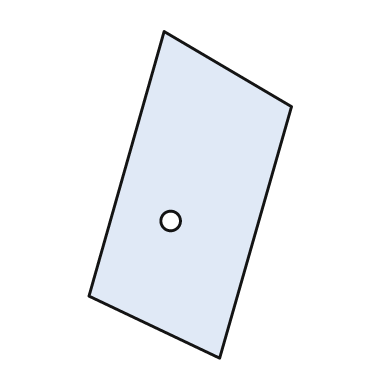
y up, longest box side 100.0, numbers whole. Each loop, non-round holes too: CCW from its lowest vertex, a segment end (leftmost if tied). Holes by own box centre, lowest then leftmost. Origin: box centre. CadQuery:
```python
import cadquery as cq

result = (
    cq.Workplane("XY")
    .moveTo(9.0, -50.0)
    .lineTo(31.0, 27.0)
    .lineTo(-8.0, 50.0)
    .lineTo(-31.0, -31.0)
    .close()
    .moveTo(-6.0, -8.0)
    .circle(3.0)
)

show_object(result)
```